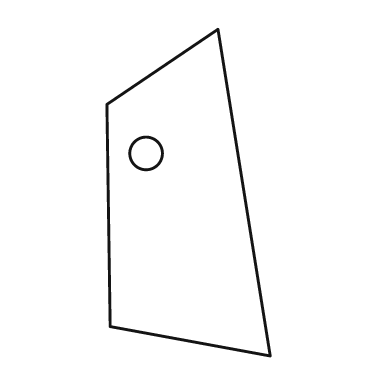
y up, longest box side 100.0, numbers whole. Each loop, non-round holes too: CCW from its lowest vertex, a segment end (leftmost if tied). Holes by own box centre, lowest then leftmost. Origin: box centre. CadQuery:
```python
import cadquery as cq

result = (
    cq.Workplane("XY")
    .moveTo(25.0, -50.0)
    .lineTo(9.0, 50.0)
    .lineTo(-25.0, 27.0)
    .lineTo(-24.0, -41.0)
    .close()
    .moveTo(-13.0, 12.0)
    .circle(5.0)
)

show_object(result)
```